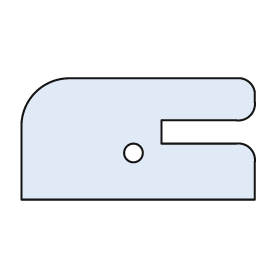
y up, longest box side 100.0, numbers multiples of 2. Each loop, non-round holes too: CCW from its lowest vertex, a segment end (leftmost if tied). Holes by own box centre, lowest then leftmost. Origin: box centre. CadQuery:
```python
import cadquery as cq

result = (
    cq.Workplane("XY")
    .moveTo(-50.0, -26.0)
    .lineTo(50.0, -26.0)
    .lineTo(50.0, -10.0)
    .threePointArc((48.0, -4.0), (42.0, -2.0))
    .lineTo(10.0, -2.0)
    .lineTo(10.0, 8.0)
    .lineTo(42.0, 8.0)
    .threePointArc((48.0, 10.0), (50.0, 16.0))
    .lineTo(50.0, 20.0)
    .threePointArc((48.0, 24.0), (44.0, 26.0))
    .lineTo(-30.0, 26.0)
    .threePointArc((-44.0, 20.0), (-50.0, 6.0))
    .close()
    .moveTo(-2.0, -6.0)
    .circle(4.0)
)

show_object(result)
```